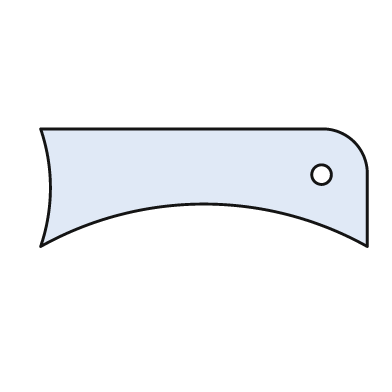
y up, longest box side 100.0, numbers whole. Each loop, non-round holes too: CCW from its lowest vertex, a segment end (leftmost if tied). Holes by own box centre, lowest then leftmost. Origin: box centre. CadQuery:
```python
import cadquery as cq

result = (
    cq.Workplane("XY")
    .moveTo(-50.0, -18.0)
    .threePointArc((0.0, -5.0), (50.0, -18.0))
    .lineTo(50.0, 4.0)
    .threePointArc((46.0, 14.0), (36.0, 18.0))
    .lineTo(-50.0, 18.0)
    .threePointArc((-47.0, 0.0), (-50.0, -18.0))
    .close()
    .moveTo(36.0, 4.0)
    .circle(3.0)
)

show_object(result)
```